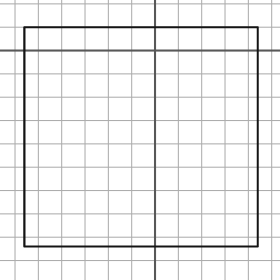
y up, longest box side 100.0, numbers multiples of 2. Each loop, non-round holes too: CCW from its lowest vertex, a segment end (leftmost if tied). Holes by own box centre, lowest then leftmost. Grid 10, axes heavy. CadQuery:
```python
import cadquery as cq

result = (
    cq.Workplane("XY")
    .moveTo(-56.0, -84.0)
    .lineTo(44.0, -84.0)
    .lineTo(44.0, 10.0)
    .lineTo(-56.0, 10.0)
    .close()
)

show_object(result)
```